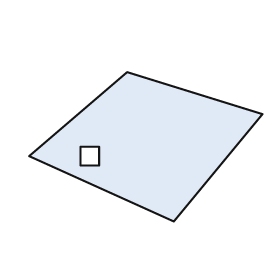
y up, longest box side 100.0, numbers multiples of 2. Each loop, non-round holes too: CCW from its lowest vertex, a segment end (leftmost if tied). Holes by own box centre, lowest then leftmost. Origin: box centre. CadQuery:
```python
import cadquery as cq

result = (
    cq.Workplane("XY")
    .moveTo(12.0, -32.0)
    .lineTo(50.0, 14.0)
    .lineTo(-8.0, 32.0)
    .lineTo(-50.0, -4.0)
    .close()
    .moveTo(-28.0, -8.0)
    .lineTo(-20.0, -8.0)
    .lineTo(-20.0, 0.0)
    .lineTo(-28.0, 0.0)
    .close()
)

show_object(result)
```